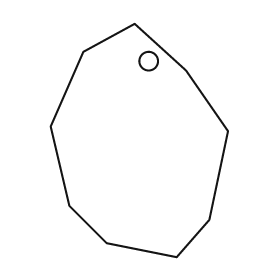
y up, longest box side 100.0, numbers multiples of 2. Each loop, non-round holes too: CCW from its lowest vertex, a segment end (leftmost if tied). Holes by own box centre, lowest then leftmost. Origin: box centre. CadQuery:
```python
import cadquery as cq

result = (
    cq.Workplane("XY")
    .moveTo(16.0, -50.0)
    .lineTo(30.0, -34.0)
    .lineTo(38.0, 4.0)
    .lineTo(20.0, 30.0)
    .lineTo(-2.0, 50.0)
    .lineTo(-24.0, 38.0)
    .lineTo(-38.0, 6.0)
    .lineTo(-30.0, -28.0)
    .lineTo(-14.0, -44.0)
    .close()
    .moveTo(4.0, 34.0)
    .circle(4.0)
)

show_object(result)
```